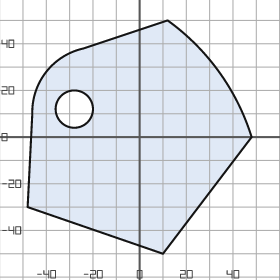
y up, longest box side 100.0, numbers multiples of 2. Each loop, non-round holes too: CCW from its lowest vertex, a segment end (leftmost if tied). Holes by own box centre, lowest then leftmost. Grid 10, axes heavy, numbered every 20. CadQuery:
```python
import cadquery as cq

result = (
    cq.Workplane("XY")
    .moveTo(10.0, -50.0)
    .lineTo(48.0, 0.0)
    .threePointArc((34.0, 28.0), (12.0, 50.0))
    .lineTo(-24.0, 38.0)
    .threePointArc((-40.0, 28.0), (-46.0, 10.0))
    .lineTo(-48.0, -30.0)
    .close()
    .moveTo(-28.0, 12.0)
    .circle(8.0)
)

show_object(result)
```